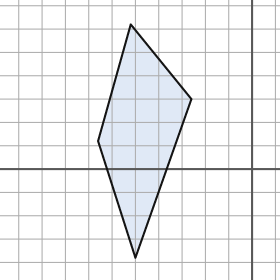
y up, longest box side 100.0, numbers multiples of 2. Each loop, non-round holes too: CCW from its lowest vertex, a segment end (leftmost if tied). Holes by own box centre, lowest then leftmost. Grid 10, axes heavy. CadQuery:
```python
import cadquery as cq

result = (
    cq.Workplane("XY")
    .moveTo(-50.0, -38.0)
    .lineTo(-26.0, 30.0)
    .lineTo(-52.0, 62.0)
    .lineTo(-66.0, 12.0)
    .close()
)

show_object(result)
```